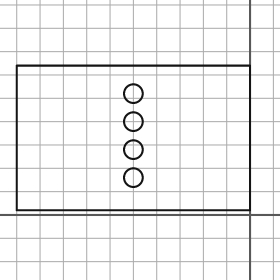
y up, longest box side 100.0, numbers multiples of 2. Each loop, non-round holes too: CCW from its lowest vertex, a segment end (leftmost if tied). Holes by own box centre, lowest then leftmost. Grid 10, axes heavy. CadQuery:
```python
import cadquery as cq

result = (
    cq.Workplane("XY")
    .moveTo(-100.0, 2.0)
    .lineTo(0.0, 2.0)
    .lineTo(0.0, 64.0)
    .lineTo(-100.0, 64.0)
    .close()
    .moveTo(-50.0, 16.0)
    .circle(4.0)
    .moveTo(-50.0, 28.0)
    .circle(4.0)
    .moveTo(-50.0, 40.0)
    .circle(4.0)
    .moveTo(-50.0, 52.0)
    .circle(4.0)
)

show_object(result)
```